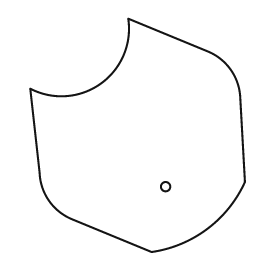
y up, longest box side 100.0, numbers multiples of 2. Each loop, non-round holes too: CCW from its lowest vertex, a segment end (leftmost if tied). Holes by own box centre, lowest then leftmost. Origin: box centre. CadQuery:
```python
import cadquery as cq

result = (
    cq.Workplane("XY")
    .moveTo(6.0, -50.0)
    .threePointArc((30.0, -40.0), (46.0, -20.0))
    .lineTo(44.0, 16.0)
    .threePointArc((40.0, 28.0), (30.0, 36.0))
    .lineTo(-4.0, 50.0)
    .threePointArc((-16.0, 22.0), (-46.0, 20.0))
    .lineTo(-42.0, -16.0)
    .threePointArc((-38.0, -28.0), (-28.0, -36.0))
    .close()
    .moveTo(12.0, -22.0)
    .circle(2.0)
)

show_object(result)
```